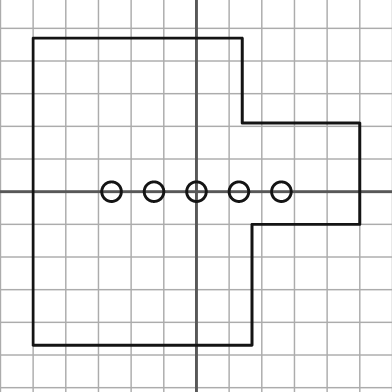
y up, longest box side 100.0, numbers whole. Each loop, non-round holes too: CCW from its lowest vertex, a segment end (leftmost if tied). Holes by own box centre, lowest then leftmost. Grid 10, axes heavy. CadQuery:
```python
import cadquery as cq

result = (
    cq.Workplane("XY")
    .moveTo(-50.0, -47.0)
    .lineTo(17.0, -47.0)
    .lineTo(17.0, -10.0)
    .lineTo(50.0, -10.0)
    .lineTo(50.0, 21.0)
    .lineTo(14.0, 21.0)
    .lineTo(14.0, 47.0)
    .lineTo(-50.0, 47.0)
    .close()
    .moveTo(-26.0, 0.0)
    .circle(3.0)
    .moveTo(-13.0, 0.0)
    .circle(3.0)
    .moveTo(0.0, 0.0)
    .circle(3.0)
    .moveTo(13.0, 0.0)
    .circle(3.0)
    .moveTo(26.0, 0.0)
    .circle(3.0)
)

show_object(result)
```